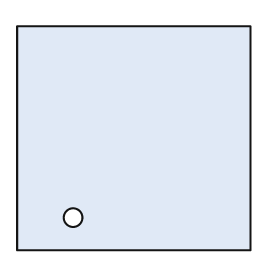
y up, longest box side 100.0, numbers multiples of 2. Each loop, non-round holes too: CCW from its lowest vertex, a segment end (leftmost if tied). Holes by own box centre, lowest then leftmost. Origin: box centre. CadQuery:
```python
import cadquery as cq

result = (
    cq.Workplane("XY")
    .moveTo(-50.0, -48.0)
    .lineTo(50.0, -48.0)
    .lineTo(50.0, 48.0)
    .lineTo(-50.0, 48.0)
    .close()
    .moveTo(-26.0, -34.0)
    .circle(4.0)
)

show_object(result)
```